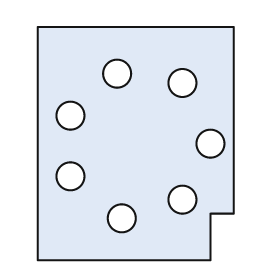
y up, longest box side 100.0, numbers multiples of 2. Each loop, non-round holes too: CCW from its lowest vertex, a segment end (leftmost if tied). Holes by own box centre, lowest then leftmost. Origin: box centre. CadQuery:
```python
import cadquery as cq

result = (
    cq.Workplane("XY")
    .moveTo(-42.0, -50.0)
    .lineTo(32.0, -50.0)
    .lineTo(32.0, -30.0)
    .lineTo(42.0, -30.0)
    .lineTo(42.0, 50.0)
    .lineTo(-42.0, 50.0)
    .close()
    .moveTo(-6.0, -32.0)
    .circle(6.0)
    .moveTo(20.0, -24.0)
    .circle(6.0)
    .moveTo(-28.0, -14.0)
    .circle(6.0)
    .moveTo(32.0, 0.0)
    .circle(6.0)
    .moveTo(-28.0, 12.0)
    .circle(6.0)
    .moveTo(20.0, 26.0)
    .circle(6.0)
    .moveTo(-8.0, 30.0)
    .circle(6.0)
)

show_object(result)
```